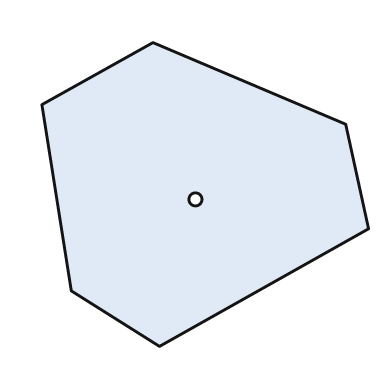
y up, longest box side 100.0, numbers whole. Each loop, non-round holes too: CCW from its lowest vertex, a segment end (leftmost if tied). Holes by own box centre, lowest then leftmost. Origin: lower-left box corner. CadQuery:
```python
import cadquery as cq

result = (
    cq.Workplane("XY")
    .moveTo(36.0, 0.0)
    .lineTo(100.0, 36.0)
    .lineTo(93.0, 68.0)
    .lineTo(34.0, 93.0)
    .lineTo(0.0, 74.0)
    .lineTo(9.0, 17.0)
    .close()
    .moveTo(47.0, 45.0)
    .circle(2.0)
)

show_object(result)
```